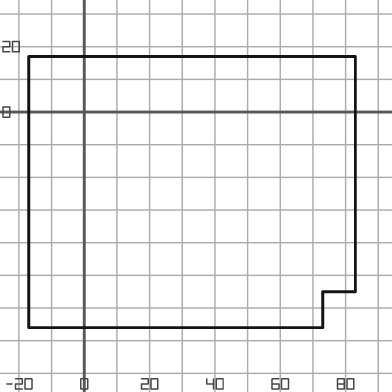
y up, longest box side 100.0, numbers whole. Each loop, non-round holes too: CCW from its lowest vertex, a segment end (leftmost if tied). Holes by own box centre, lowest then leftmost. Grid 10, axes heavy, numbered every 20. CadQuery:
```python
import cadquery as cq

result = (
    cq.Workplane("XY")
    .moveTo(-17.0, -66.0)
    .lineTo(73.0, -66.0)
    .lineTo(73.0, -55.0)
    .lineTo(83.0, -55.0)
    .lineTo(83.0, 17.0)
    .lineTo(-17.0, 17.0)
    .close()
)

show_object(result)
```